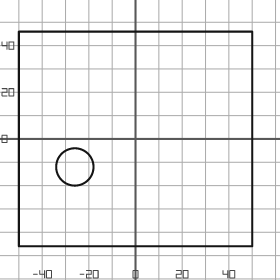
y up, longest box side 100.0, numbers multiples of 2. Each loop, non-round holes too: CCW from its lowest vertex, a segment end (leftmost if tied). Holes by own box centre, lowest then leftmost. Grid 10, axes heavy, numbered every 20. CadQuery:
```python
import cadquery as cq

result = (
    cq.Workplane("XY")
    .moveTo(-50.0, -46.0)
    .lineTo(50.0, -46.0)
    .lineTo(50.0, 46.0)
    .lineTo(-50.0, 46.0)
    .close()
    .moveTo(-26.0, -12.0)
    .circle(8.0)
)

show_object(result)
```